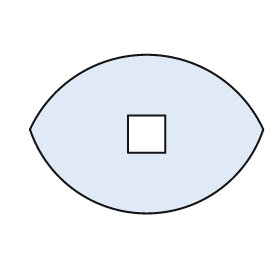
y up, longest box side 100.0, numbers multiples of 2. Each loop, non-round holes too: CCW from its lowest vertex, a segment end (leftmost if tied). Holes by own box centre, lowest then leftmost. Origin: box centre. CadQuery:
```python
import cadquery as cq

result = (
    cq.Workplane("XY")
    .moveTo(-50.0, 2.0)
    .threePointArc((0.0, -34.0), (50.0, 2.0))
    .threePointArc((0.0, 34.0), (-50.0, 2.0))
    .close()
    .moveTo(-8.0, -8.0)
    .lineTo(8.0, -8.0)
    .lineTo(8.0, 8.0)
    .lineTo(-8.0, 8.0)
    .close()
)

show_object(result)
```